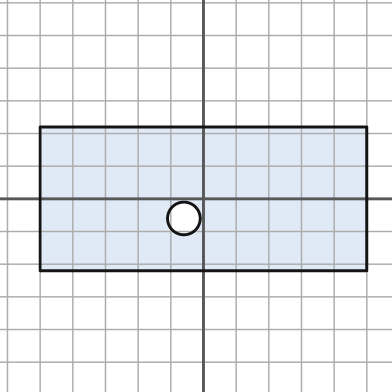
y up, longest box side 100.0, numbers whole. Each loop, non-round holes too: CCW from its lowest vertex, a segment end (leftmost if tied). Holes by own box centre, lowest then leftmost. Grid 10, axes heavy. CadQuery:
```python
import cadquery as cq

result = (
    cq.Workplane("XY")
    .moveTo(-50.0, -22.0)
    .lineTo(50.0, -22.0)
    .lineTo(50.0, 22.0)
    .lineTo(-50.0, 22.0)
    .close()
    .moveTo(-6.0, -6.0)
    .circle(5.0)
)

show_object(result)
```